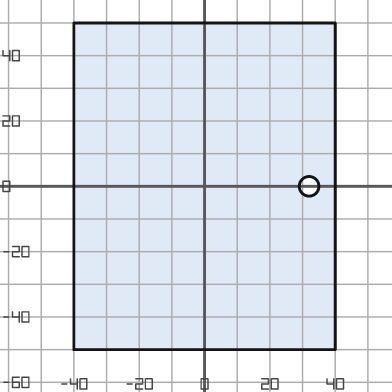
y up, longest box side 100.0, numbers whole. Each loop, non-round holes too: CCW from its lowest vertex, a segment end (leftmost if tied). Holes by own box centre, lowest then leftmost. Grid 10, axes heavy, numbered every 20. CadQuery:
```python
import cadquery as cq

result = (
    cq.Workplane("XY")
    .moveTo(-40.0, -50.0)
    .lineTo(40.0, -50.0)
    .lineTo(40.0, 50.0)
    .lineTo(-40.0, 50.0)
    .close()
    .moveTo(32.0, 0.0)
    .circle(3.0)
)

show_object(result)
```